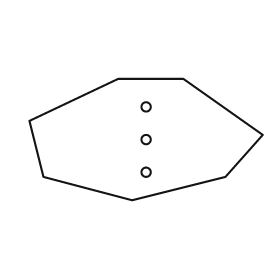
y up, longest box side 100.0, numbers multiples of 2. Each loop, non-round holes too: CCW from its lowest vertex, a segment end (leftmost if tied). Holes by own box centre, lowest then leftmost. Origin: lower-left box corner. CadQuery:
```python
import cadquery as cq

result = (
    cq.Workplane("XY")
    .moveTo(44.0, 0.0)
    .lineTo(84.0, 10.0)
    .lineTo(100.0, 28.0)
    .lineTo(66.0, 52.0)
    .lineTo(38.0, 52.0)
    .lineTo(0.0, 34.0)
    .lineTo(6.0, 10.0)
    .close()
    .moveTo(50.0, 12.0)
    .circle(2.0)
    .moveTo(50.0, 26.0)
    .circle(2.0)
    .moveTo(50.0, 40.0)
    .circle(2.0)
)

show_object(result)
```